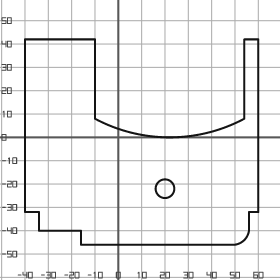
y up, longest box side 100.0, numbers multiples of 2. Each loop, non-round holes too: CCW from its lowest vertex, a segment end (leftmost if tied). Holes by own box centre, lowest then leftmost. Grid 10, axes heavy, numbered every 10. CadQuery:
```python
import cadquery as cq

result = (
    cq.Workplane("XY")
    .moveTo(-16.0, -46.0)
    .lineTo(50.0, -46.0)
    .threePointArc((54.0, -44.0), (56.0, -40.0))
    .lineTo(56.0, -32.0)
    .lineTo(60.0, -32.0)
    .lineTo(60.0, 42.0)
    .lineTo(54.0, 42.0)
    .lineTo(54.0, 8.0)
    .threePointArc((22.0, 0.0), (-10.0, 8.0))
    .lineTo(-10.0, 42.0)
    .lineTo(-40.0, 42.0)
    .lineTo(-40.0, -32.0)
    .lineTo(-34.0, -32.0)
    .lineTo(-34.0, -40.0)
    .lineTo(-16.0, -40.0)
    .close()
    .moveTo(20.0, -22.0)
    .circle(4.0)
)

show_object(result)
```